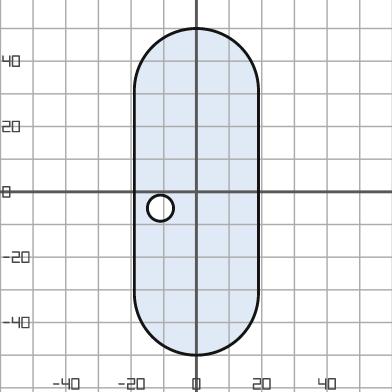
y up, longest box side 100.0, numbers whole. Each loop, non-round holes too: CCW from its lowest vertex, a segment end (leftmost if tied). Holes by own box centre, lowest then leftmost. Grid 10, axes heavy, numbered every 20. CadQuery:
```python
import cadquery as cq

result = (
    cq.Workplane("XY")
    .moveTo(-19.0, -31.0)
    .threePointArc((0.0, -50.0), (19.0, -31.0))
    .lineTo(19.0, 31.0)
    .threePointArc((0.0, 50.0), (-19.0, 31.0))
    .close()
    .moveTo(-11.0, -5.0)
    .circle(4.0)
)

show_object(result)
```